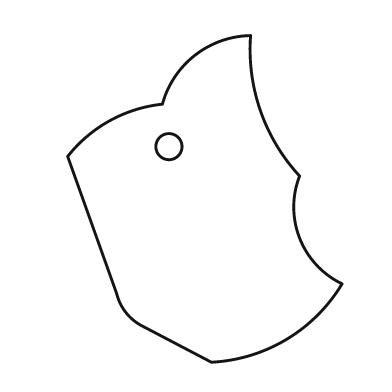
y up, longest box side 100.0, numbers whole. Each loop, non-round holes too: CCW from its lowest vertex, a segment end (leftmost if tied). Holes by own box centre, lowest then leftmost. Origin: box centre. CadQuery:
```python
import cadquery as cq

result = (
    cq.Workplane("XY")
    .moveTo(2.0, -50.0)
    .threePointArc((25.0, -43.0), (42.0, -26.0))
    .threePointArc((29.0, -12.0), (29.0, 7.0))
    .threePointArc((17.0, 27.0), (14.0, 50.0))
    .threePointArc((-3.0, 44.0), (-13.0, 29.0))
    .threePointArc((-29.0, 24.0), (-42.0, 13.0))
    .lineTo(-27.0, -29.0)
    .threePointArc((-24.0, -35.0), (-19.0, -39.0))
    .close()
    .moveTo(-11.0, 16.0)
    .circle(4.0)
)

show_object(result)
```